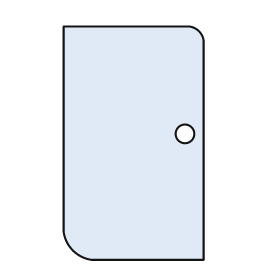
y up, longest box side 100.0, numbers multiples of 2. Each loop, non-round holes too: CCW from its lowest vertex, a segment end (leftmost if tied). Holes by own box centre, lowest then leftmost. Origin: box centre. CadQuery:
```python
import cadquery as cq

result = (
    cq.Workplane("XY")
    .moveTo(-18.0, -50.0)
    .lineTo(30.0, -50.0)
    .lineTo(30.0, 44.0)
    .threePointArc((28.0, 48.0), (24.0, 50.0))
    .lineTo(-30.0, 50.0)
    .lineTo(-30.0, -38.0)
    .threePointArc((-26.0, -46.0), (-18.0, -50.0))
    .close()
    .moveTo(22.0, 4.0)
    .circle(4.0)
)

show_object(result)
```